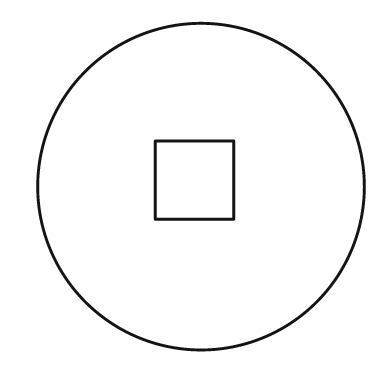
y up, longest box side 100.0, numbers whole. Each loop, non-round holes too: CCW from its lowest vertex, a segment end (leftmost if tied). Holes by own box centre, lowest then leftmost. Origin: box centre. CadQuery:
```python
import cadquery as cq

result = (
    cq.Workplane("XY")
    .moveTo(0.0, 0.0)
    .circle(50.0)
    .moveTo(-14.0, -10.0)
    .lineTo(10.0, -10.0)
    .lineTo(10.0, 14.0)
    .lineTo(-14.0, 14.0)
    .close()
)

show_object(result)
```